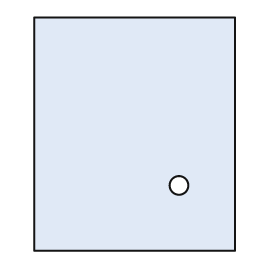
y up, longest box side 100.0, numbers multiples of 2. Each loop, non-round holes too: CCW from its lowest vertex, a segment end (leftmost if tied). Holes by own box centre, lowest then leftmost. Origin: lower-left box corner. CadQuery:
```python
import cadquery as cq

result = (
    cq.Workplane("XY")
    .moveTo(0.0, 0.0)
    .lineTo(86.0, 0.0)
    .lineTo(86.0, 100.0)
    .lineTo(0.0, 100.0)
    .close()
    .moveTo(62.0, 28.0)
    .circle(4.0)
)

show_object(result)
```